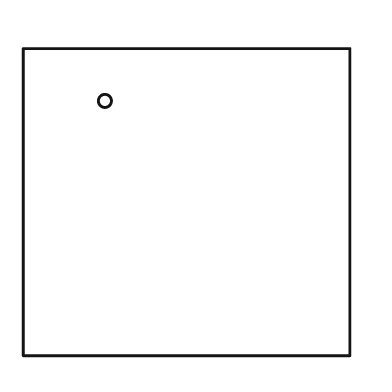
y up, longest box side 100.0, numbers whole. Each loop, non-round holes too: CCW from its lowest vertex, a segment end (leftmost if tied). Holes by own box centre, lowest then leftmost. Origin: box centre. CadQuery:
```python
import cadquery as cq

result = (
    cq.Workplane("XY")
    .moveTo(-50.0, -47.0)
    .lineTo(50.0, -47.0)
    .lineTo(50.0, 47.0)
    .lineTo(-50.0, 47.0)
    .close()
    .moveTo(-25.0, 31.0)
    .circle(2.0)
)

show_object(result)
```